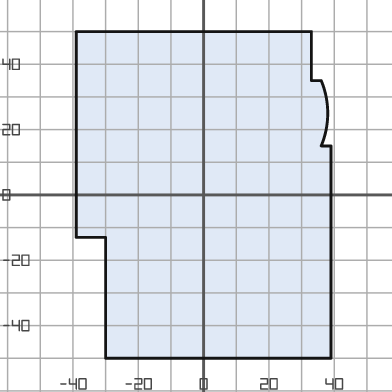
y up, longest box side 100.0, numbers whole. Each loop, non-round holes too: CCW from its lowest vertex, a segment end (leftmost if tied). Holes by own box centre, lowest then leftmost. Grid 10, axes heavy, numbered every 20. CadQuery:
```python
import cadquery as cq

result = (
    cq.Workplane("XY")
    .moveTo(-30.0, -50.0)
    .lineTo(39.0, -50.0)
    .lineTo(39.0, 15.0)
    .lineTo(36.0, 15.0)
    .threePointArc((38.0, 25.0), (36.0, 35.0))
    .lineTo(33.0, 35.0)
    .lineTo(33.0, 50.0)
    .lineTo(-39.0, 50.0)
    .lineTo(-39.0, -13.0)
    .lineTo(-30.0, -13.0)
    .close()
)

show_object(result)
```